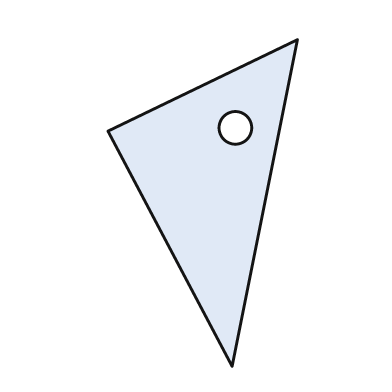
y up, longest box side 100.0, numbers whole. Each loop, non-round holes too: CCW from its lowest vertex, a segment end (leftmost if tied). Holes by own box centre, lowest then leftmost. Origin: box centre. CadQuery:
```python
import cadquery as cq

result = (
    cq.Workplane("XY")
    .moveTo(9.0, -50.0)
    .lineTo(29.0, 50.0)
    .lineTo(-29.0, 22.0)
    .close()
    .moveTo(10.0, 23.0)
    .circle(5.0)
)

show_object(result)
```